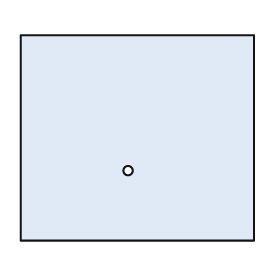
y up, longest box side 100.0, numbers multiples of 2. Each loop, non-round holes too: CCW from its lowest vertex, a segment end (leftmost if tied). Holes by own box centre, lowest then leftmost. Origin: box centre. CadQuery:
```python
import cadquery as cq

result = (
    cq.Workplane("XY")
    .moveTo(-50.0, -44.0)
    .lineTo(50.0, -44.0)
    .lineTo(50.0, 44.0)
    .lineTo(-50.0, 44.0)
    .close()
    .moveTo(-4.0, -14.0)
    .circle(2.0)
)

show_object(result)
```